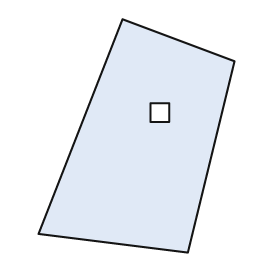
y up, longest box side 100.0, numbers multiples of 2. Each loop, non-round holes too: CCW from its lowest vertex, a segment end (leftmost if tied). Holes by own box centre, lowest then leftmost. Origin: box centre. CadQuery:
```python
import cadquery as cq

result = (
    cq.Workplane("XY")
    .moveTo(22.0, -50.0)
    .lineTo(42.0, 32.0)
    .lineTo(-6.0, 50.0)
    .lineTo(-42.0, -42.0)
    .close()
    .moveTo(6.0, 6.0)
    .lineTo(14.0, 6.0)
    .lineTo(14.0, 14.0)
    .lineTo(6.0, 14.0)
    .close()
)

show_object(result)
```